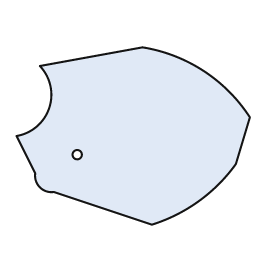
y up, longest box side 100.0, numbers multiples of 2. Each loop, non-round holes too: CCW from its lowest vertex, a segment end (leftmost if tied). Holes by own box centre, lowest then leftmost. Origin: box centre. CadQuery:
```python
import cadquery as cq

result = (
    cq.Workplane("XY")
    .moveTo(8.0, -38.0)
    .threePointArc((28.0, -28.0), (44.0, -12.0))
    .lineTo(50.0, 8.0)
    .threePointArc((30.0, 28.0), (4.0, 38.0))
    .lineTo(-40.0, 30.0)
    .threePointArc((-36.0, 12.0), (-50.0, 0.0))
    .lineTo(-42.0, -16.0)
    .threePointArc((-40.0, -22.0), (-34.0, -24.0))
    .close()
    .moveTo(-24.0, -8.0)
    .circle(2.0)
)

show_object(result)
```